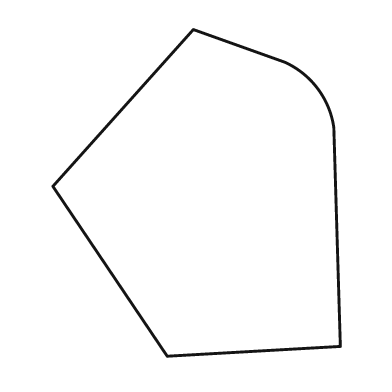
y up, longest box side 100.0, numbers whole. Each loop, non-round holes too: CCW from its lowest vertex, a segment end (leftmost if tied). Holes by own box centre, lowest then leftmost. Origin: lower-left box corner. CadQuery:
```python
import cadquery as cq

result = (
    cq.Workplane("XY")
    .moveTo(35.0, 0.0)
    .lineTo(88.0, 3.0)
    .lineTo(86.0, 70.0)
    .threePointArc((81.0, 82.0), (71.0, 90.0))
    .lineTo(43.0, 100.0)
    .lineTo(0.0, 52.0)
    .close()
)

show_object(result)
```